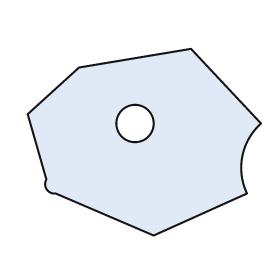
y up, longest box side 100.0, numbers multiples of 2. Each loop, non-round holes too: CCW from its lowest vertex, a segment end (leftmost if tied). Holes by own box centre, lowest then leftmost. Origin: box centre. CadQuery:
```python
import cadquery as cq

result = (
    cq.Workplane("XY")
    .moveTo(4.0, -40.0)
    .lineTo(44.0, -22.0)
    .threePointArc((42.0, -6.0), (50.0, 8.0))
    .lineTo(20.0, 40.0)
    .lineTo(-28.0, 32.0)
    .lineTo(-50.0, 12.0)
    .lineTo(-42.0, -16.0)
    .threePointArc((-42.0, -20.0), (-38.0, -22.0))
    .close()
    .moveTo(-4.0, 8.0)
    .circle(8.0)
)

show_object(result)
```